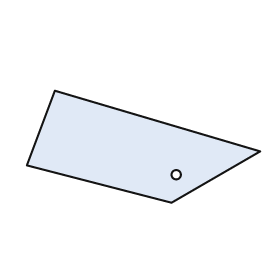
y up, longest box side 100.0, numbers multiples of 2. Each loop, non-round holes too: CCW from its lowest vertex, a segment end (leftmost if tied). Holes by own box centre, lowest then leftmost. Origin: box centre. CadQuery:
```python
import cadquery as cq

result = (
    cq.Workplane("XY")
    .moveTo(12.0, -24.0)
    .lineTo(50.0, -2.0)
    .lineTo(-38.0, 24.0)
    .lineTo(-50.0, -8.0)
    .close()
    .moveTo(14.0, -12.0)
    .circle(2.0)
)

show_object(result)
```